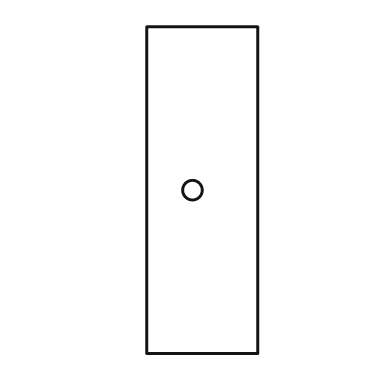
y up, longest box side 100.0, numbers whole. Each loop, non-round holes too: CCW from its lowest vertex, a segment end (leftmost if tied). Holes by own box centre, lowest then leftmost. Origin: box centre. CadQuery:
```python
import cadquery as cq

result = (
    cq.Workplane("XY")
    .moveTo(-17.0, -50.0)
    .lineTo(17.0, -50.0)
    .lineTo(17.0, 50.0)
    .lineTo(-17.0, 50.0)
    .close()
    .moveTo(-3.0, 0.0)
    .circle(3.0)
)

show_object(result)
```